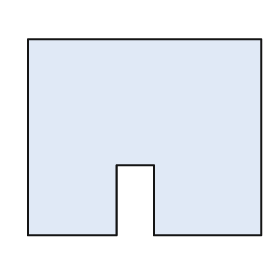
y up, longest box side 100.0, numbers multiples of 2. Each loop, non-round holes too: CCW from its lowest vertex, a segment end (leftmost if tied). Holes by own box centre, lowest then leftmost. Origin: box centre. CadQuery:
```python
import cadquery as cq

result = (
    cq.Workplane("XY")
    .moveTo(-50.0, -42.0)
    .lineTo(-12.0, -42.0)
    .lineTo(-12.0, -12.0)
    .lineTo(4.0, -12.0)
    .lineTo(4.0, -42.0)
    .lineTo(50.0, -42.0)
    .lineTo(50.0, 42.0)
    .lineTo(-50.0, 42.0)
    .close()
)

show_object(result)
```